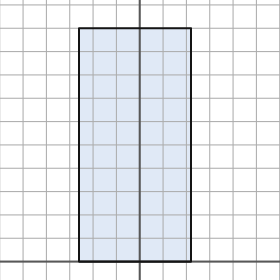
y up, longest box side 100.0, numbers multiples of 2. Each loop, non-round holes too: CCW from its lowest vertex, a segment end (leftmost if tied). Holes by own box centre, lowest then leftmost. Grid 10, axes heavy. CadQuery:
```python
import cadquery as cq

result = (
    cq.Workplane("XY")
    .moveTo(-26.0, 0.0)
    .lineTo(22.0, 0.0)
    .lineTo(22.0, 100.0)
    .lineTo(-26.0, 100.0)
    .close()
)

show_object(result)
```